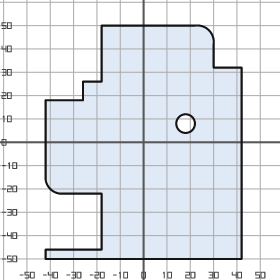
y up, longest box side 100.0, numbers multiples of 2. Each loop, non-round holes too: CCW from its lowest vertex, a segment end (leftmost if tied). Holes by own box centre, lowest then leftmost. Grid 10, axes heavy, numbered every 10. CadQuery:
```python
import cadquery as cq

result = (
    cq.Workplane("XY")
    .moveTo(-42.0, -50.0)
    .lineTo(42.0, -50.0)
    .lineTo(42.0, 32.0)
    .lineTo(30.0, 32.0)
    .lineTo(30.0, 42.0)
    .threePointArc((28.0, 48.0), (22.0, 50.0))
    .lineTo(-18.0, 50.0)
    .lineTo(-18.0, 26.0)
    .lineTo(-26.0, 26.0)
    .lineTo(-26.0, 18.0)
    .lineTo(-42.0, 18.0)
    .lineTo(-42.0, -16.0)
    .threePointArc((-40.0, -20.0), (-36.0, -22.0))
    .lineTo(-18.0, -22.0)
    .lineTo(-18.0, -46.0)
    .lineTo(-42.0, -46.0)
    .close()
    .moveTo(18.0, 8.0)
    .circle(4.0)
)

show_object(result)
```